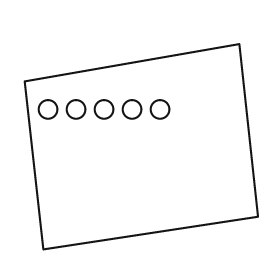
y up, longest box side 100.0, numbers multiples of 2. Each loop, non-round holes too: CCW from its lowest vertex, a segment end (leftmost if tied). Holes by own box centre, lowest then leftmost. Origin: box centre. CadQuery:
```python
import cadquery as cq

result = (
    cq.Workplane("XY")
    .moveTo(-42.0, -44.0)
    .lineTo(50.0, -30.0)
    .lineTo(42.0, 44.0)
    .lineTo(-50.0, 28.0)
    .close()
    .moveTo(-40.0, 16.0)
    .circle(4.0)
    .moveTo(-28.0, 16.0)
    .circle(4.0)
    .moveTo(-16.0, 16.0)
    .circle(4.0)
    .moveTo(-4.0, 16.0)
    .circle(4.0)
    .moveTo(8.0, 16.0)
    .circle(4.0)
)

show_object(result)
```